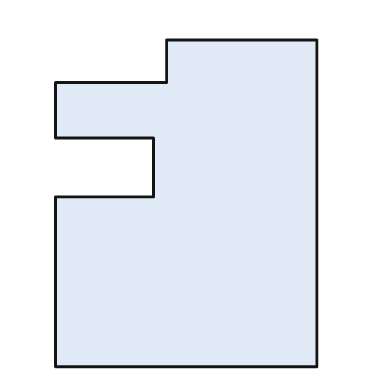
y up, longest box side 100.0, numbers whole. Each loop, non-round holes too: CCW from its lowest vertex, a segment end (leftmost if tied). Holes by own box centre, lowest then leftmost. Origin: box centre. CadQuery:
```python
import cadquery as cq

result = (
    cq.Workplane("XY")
    .moveTo(-40.0, -50.0)
    .lineTo(40.0, -50.0)
    .lineTo(40.0, 50.0)
    .lineTo(-6.0, 50.0)
    .lineTo(-6.0, 37.0)
    .lineTo(-40.0, 37.0)
    .lineTo(-40.0, 20.0)
    .lineTo(-10.0, 20.0)
    .lineTo(-10.0, 2.0)
    .lineTo(-40.0, 2.0)
    .close()
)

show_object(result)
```